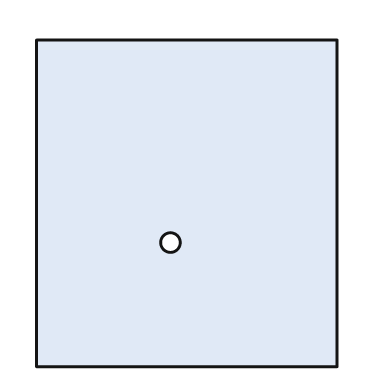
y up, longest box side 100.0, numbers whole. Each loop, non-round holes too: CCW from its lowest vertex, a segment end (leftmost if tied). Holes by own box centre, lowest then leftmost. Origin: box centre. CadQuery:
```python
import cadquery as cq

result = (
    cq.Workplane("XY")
    .moveTo(-46.0, -50.0)
    .lineTo(46.0, -50.0)
    .lineTo(46.0, 50.0)
    .lineTo(-46.0, 50.0)
    .close()
    .moveTo(-5.0, -12.0)
    .circle(3.0)
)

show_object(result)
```